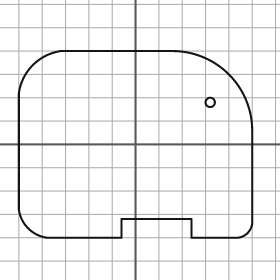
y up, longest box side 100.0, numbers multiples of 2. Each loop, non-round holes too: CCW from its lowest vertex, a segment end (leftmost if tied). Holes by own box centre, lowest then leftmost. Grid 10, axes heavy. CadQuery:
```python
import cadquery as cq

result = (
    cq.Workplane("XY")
    .moveTo(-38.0, -40.0)
    .lineTo(-6.0, -40.0)
    .lineTo(-6.0, -32.0)
    .lineTo(24.0, -32.0)
    .lineTo(24.0, -40.0)
    .lineTo(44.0, -40.0)
    .threePointArc((48.0, -38.0), (50.0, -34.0))
    .lineTo(50.0, 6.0)
    .threePointArc((40.0, 30.0), (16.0, 40.0))
    .lineTo(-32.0, 40.0)
    .threePointArc((-44.0, 34.0), (-50.0, 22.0))
    .lineTo(-50.0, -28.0)
    .threePointArc((-46.0, -36.0), (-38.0, -40.0))
    .close()
    .moveTo(32.0, 18.0)
    .circle(2.0)
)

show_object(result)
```